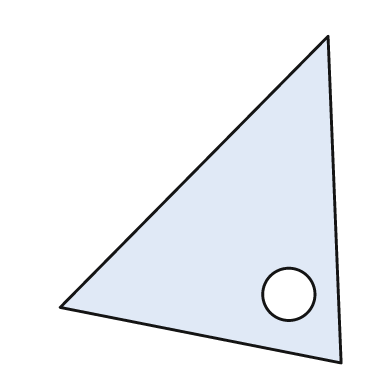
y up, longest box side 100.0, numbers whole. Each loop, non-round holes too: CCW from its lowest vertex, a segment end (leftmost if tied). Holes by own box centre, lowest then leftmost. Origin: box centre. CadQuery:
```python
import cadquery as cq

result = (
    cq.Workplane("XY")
    .moveTo(43.0, -50.0)
    .lineTo(39.0, 50.0)
    .lineTo(-43.0, -33.0)
    .close()
    .moveTo(27.0, -29.0)
    .circle(8.0)
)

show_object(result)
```